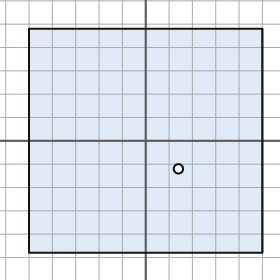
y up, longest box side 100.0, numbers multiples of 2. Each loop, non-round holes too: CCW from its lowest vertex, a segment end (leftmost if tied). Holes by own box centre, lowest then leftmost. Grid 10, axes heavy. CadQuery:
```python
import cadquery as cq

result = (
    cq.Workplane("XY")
    .moveTo(-50.0, -48.0)
    .lineTo(50.0, -48.0)
    .lineTo(50.0, 48.0)
    .lineTo(-50.0, 48.0)
    .close()
    .moveTo(14.0, -12.0)
    .circle(2.0)
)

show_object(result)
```